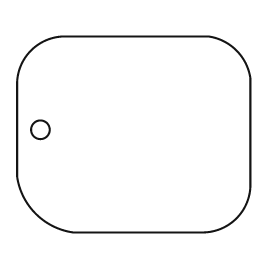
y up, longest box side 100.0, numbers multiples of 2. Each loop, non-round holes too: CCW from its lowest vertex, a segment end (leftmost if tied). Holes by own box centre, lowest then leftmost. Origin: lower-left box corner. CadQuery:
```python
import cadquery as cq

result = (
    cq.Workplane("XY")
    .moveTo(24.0, 0.0)
    .lineTo(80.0, 0.0)
    .threePointArc((94.0, 6.0), (100.0, 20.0))
    .lineTo(100.0, 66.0)
    .threePointArc((94.0, 78.0), (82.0, 84.0))
    .lineTo(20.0, 84.0)
    .threePointArc((6.0, 78.0), (0.0, 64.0))
    .lineTo(0.0, 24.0)
    .threePointArc((8.0, 8.0), (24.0, 0.0))
    .close()
    .moveTo(10.0, 44.0)
    .circle(4.0)
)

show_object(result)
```